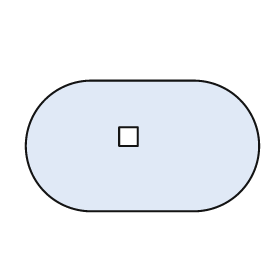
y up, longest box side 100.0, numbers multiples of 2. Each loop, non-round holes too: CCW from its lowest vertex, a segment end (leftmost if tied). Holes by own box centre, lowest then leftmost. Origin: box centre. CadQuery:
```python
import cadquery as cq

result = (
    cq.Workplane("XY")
    .moveTo(-22.0, -28.0)
    .lineTo(22.0, -28.0)
    .threePointArc((50.0, 0.0), (22.0, 28.0))
    .lineTo(-22.0, 28.0)
    .threePointArc((-50.0, 0.0), (-22.0, -28.0))
    .close()
    .moveTo(-10.0, 0.0)
    .lineTo(-2.0, 0.0)
    .lineTo(-2.0, 8.0)
    .lineTo(-10.0, 8.0)
    .close()
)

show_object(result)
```